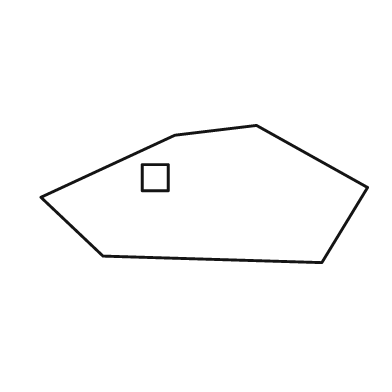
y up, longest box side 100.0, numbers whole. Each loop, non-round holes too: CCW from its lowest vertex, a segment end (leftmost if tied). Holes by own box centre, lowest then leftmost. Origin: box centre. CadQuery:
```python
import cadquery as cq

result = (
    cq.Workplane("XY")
    .moveTo(36.0, -21.0)
    .lineTo(50.0, 2.0)
    .lineTo(16.0, 21.0)
    .lineTo(-9.0, 18.0)
    .lineTo(-50.0, -1.0)
    .lineTo(-31.0, -19.0)
    .close()
    .moveTo(-19.0, 1.0)
    .lineTo(-11.0, 1.0)
    .lineTo(-11.0, 9.0)
    .lineTo(-19.0, 9.0)
    .close()
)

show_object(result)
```